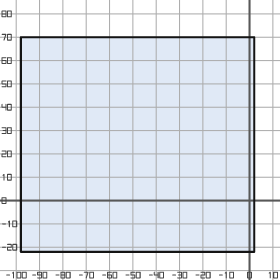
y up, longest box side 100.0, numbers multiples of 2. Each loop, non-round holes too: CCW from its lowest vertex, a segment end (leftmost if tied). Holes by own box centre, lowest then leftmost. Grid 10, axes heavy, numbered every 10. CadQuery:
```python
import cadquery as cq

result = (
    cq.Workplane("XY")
    .moveTo(-98.0, -22.0)
    .lineTo(2.0, -22.0)
    .lineTo(2.0, 70.0)
    .lineTo(-98.0, 70.0)
    .close()
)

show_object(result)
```